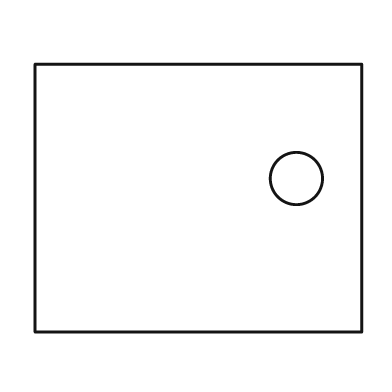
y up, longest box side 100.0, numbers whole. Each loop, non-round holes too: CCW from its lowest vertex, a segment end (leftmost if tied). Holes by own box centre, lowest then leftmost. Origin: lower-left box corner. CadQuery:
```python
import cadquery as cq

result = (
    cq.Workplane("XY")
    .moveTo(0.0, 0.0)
    .lineTo(100.0, 0.0)
    .lineTo(100.0, 82.0)
    .lineTo(0.0, 82.0)
    .close()
    .moveTo(80.0, 47.0)
    .circle(8.0)
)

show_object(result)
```